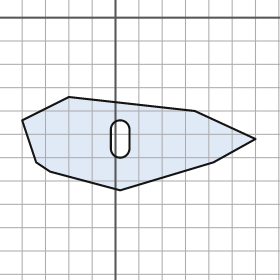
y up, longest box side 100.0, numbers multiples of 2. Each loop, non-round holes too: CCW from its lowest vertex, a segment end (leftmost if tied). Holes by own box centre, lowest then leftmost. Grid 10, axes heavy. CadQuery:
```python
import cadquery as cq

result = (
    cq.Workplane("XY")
    .moveTo(2.0, -74.0)
    .lineTo(42.0, -62.0)
    .lineTo(60.0, -52.0)
    .lineTo(34.0, -40.0)
    .lineTo(-20.0, -34.0)
    .lineTo(-40.0, -44.0)
    .lineTo(-34.0, -62.0)
    .lineTo(-28.0, -66.0)
    .close()
    .moveTo(-2.0, -56.0)
    .threePointArc((2.0, -60.0), (6.0, -56.0))
    .lineTo(6.0, -48.0)
    .threePointArc((2.0, -44.0), (-2.0, -48.0))
    .close()
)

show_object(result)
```